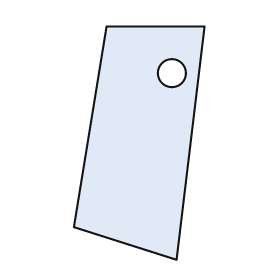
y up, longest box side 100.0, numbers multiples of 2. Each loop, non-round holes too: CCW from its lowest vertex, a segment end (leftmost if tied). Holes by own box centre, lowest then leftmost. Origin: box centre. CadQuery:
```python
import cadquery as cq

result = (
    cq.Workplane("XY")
    .moveTo(16.0, -50.0)
    .lineTo(28.0, 50.0)
    .lineTo(-14.0, 50.0)
    .lineTo(-28.0, -36.0)
    .close()
    .moveTo(14.0, 30.0)
    .circle(6.0)
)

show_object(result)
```